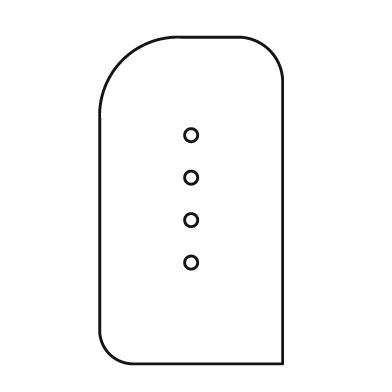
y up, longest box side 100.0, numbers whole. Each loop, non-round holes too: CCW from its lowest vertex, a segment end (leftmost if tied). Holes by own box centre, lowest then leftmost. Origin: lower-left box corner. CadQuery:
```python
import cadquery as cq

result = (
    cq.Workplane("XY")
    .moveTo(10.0, 0.0)
    .lineTo(56.0, 0.0)
    .lineTo(56.0, 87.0)
    .threePointArc((52.0, 96.0), (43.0, 100.0))
    .lineTo(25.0, 100.0)
    .threePointArc((7.0, 93.0), (0.0, 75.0))
    .lineTo(0.0, 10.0)
    .threePointArc((3.0, 3.0), (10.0, 0.0))
    .close()
    .moveTo(28.0, 31.0)
    .circle(2.0)
    .moveTo(28.0, 44.0)
    .circle(2.0)
    .moveTo(28.0, 57.0)
    .circle(2.0)
    .moveTo(28.0, 70.0)
    .circle(2.0)
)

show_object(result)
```